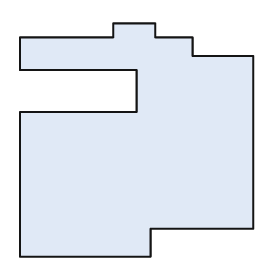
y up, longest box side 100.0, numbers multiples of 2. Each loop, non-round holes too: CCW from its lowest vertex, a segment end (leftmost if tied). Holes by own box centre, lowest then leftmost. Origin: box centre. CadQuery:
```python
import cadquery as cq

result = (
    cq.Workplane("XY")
    .moveTo(-50.0, -50.0)
    .lineTo(6.0, -50.0)
    .lineTo(6.0, -38.0)
    .lineTo(50.0, -38.0)
    .lineTo(50.0, 36.0)
    .lineTo(24.0, 36.0)
    .lineTo(24.0, 44.0)
    .lineTo(8.0, 44.0)
    .lineTo(8.0, 50.0)
    .lineTo(-10.0, 50.0)
    .lineTo(-10.0, 44.0)
    .lineTo(-50.0, 44.0)
    .lineTo(-50.0, 30.0)
    .lineTo(0.0, 30.0)
    .lineTo(0.0, 12.0)
    .lineTo(-50.0, 12.0)
    .close()
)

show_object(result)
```